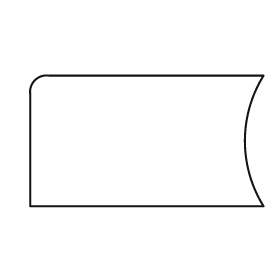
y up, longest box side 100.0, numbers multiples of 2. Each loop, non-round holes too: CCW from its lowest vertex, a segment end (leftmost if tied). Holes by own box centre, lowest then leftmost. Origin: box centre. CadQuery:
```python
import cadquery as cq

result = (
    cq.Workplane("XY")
    .moveTo(-50.0, -28.0)
    .lineTo(50.0, -28.0)
    .threePointArc((42.0, 0.0), (50.0, 28.0))
    .lineTo(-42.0, 28.0)
    .threePointArc((-48.0, 26.0), (-50.0, 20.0))
    .close()
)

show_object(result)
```